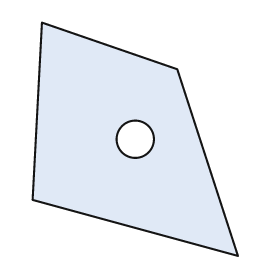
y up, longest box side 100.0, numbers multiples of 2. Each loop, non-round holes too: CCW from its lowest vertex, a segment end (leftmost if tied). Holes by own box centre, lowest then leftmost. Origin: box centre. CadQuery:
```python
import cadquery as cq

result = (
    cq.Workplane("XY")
    .moveTo(44.0, -50.0)
    .lineTo(18.0, 30.0)
    .lineTo(-40.0, 50.0)
    .lineTo(-44.0, -26.0)
    .close()
    .moveTo(0.0, 0.0)
    .circle(8.0)
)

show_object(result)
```